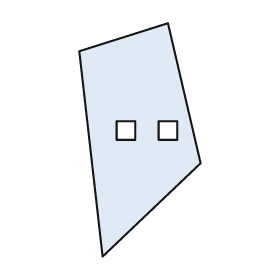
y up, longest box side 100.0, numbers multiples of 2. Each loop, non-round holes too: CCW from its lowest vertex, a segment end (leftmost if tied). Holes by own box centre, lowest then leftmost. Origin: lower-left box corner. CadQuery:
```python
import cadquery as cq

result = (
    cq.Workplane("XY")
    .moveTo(10.0, 0.0)
    .lineTo(52.0, 40.0)
    .lineTo(38.0, 100.0)
    .lineTo(0.0, 88.0)
    .close()
    .moveTo(16.0, 50.0)
    .lineTo(24.0, 50.0)
    .lineTo(24.0, 58.0)
    .lineTo(16.0, 58.0)
    .close()
    .moveTo(34.0, 50.0)
    .lineTo(42.0, 50.0)
    .lineTo(42.0, 58.0)
    .lineTo(34.0, 58.0)
    .close()
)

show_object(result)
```